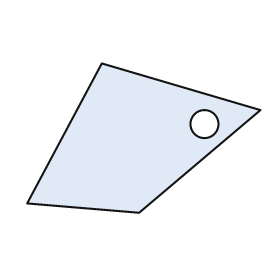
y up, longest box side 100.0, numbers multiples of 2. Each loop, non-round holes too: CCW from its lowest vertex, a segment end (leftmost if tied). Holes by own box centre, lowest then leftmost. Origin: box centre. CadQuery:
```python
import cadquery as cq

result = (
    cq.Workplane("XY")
    .moveTo(-2.0, -32.0)
    .lineTo(50.0, 12.0)
    .lineTo(-18.0, 32.0)
    .lineTo(-50.0, -28.0)
    .close()
    .moveTo(26.0, 6.0)
    .circle(6.0)
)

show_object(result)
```